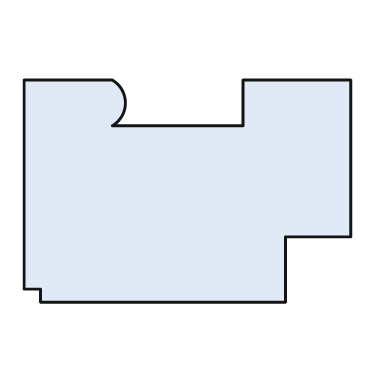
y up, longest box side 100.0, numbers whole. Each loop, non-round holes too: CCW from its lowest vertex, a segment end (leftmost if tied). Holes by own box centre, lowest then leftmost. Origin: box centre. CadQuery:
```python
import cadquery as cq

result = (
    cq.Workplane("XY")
    .moveTo(-45.0, -34.0)
    .lineTo(30.0, -34.0)
    .lineTo(30.0, -14.0)
    .lineTo(50.0, -14.0)
    .lineTo(50.0, 34.0)
    .lineTo(17.0, 34.0)
    .lineTo(17.0, 20.0)
    .lineTo(-23.0, 20.0)
    .threePointArc((-19.0, 27.0), (-23.0, 34.0))
    .lineTo(-50.0, 34.0)
    .lineTo(-50.0, -30.0)
    .lineTo(-45.0, -30.0)
    .close()
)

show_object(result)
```